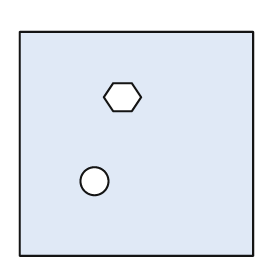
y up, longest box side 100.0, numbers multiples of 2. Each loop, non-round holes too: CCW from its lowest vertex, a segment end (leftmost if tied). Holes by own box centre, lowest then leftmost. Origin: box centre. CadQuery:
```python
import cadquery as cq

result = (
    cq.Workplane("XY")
    .moveTo(-50.0, -48.0)
    .lineTo(50.0, -48.0)
    .lineTo(50.0, 48.0)
    .lineTo(-50.0, 48.0)
    .close()
    .moveTo(-18.0, -16.0)
    .circle(6.0)
    .moveTo(-10.0, 14.0)
    .lineTo(-2.0, 14.0)
    .lineTo(2.0, 20.0)
    .lineTo(-2.0, 26.0)
    .lineTo(-10.0, 26.0)
    .lineTo(-14.0, 20.0)
    .close()
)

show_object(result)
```